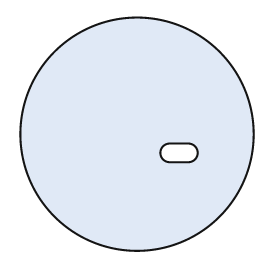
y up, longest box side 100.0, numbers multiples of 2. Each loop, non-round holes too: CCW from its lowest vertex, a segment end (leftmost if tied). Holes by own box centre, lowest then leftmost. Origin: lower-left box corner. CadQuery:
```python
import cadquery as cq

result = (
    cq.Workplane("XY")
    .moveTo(50.0, 50.0)
    .circle(50.0)
    .moveTo(64.0, 38.0)
    .lineTo(72.0, 38.0)
    .threePointArc((76.0, 42.0), (72.0, 46.0))
    .lineTo(64.0, 46.0)
    .threePointArc((60.0, 42.0), (64.0, 38.0))
    .close()
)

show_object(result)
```